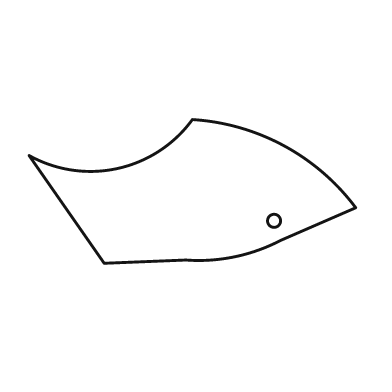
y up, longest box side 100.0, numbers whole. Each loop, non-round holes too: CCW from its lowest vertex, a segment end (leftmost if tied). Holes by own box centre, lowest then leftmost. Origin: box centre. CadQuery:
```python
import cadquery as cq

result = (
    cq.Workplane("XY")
    .moveTo(-27.0, -22.0)
    .lineTo(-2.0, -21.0)
    .threePointArc((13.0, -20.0), (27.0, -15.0))
    .lineTo(50.0, -5.0)
    .threePointArc((28.0, 14.0), (0.0, 22.0))
    .threePointArc((-23.0, 7.0), (-50.0, 11.0))
    .close()
    .moveTo(25.0, -9.0)
    .circle(2.0)
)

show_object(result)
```